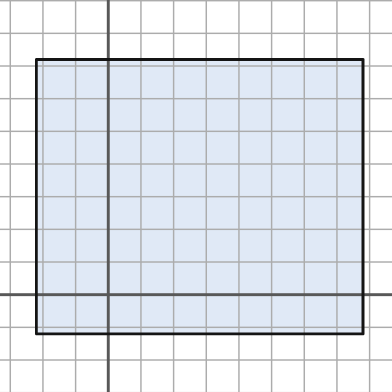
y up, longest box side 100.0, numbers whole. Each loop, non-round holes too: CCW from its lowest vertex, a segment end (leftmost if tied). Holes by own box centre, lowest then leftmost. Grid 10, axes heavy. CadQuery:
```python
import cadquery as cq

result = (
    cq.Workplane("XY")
    .moveTo(-22.0, -12.0)
    .lineTo(78.0, -12.0)
    .lineTo(78.0, 72.0)
    .lineTo(-22.0, 72.0)
    .close()
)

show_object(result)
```